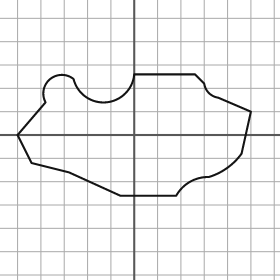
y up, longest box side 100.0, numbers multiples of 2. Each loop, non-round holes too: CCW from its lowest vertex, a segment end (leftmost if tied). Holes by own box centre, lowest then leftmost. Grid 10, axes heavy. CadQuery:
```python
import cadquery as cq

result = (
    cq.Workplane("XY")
    .moveTo(-6.0, -26.0)
    .lineTo(18.0, -26.0)
    .threePointArc((24.0, -20.0), (32.0, -18.0))
    .threePointArc((40.0, -14.0), (46.0, -8.0))
    .lineTo(50.0, 10.0)
    .lineTo(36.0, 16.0)
    .threePointArc((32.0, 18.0), (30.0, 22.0))
    .lineTo(26.0, 26.0)
    .lineTo(0.0, 26.0)
    .threePointArc((-12.0, 14.0), (-26.0, 24.0))
    .threePointArc((-36.0, 24.0), (-38.0, 14.0))
    .lineTo(-50.0, 0.0)
    .lineTo(-44.0, -12.0)
    .lineTo(-28.0, -16.0)
    .close()
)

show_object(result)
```